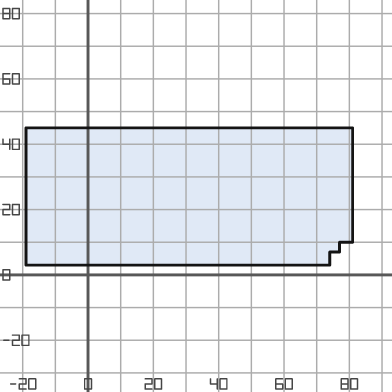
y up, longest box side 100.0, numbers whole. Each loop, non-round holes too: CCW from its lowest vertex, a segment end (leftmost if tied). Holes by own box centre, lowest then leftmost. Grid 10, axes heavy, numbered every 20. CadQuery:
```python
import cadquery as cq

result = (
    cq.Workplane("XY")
    .moveTo(-19.0, 3.0)
    .lineTo(74.0, 3.0)
    .lineTo(74.0, 7.0)
    .lineTo(77.0, 7.0)
    .lineTo(77.0, 10.0)
    .lineTo(81.0, 10.0)
    .lineTo(81.0, 45.0)
    .lineTo(-19.0, 45.0)
    .close()
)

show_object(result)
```